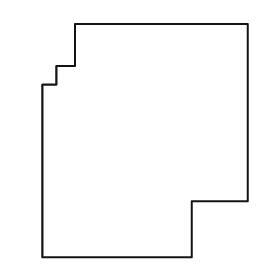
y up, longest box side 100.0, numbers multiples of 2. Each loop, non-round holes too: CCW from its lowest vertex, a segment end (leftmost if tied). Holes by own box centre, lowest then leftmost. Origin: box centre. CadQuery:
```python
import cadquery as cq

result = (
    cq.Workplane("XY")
    .moveTo(-44.0, -50.0)
    .lineTo(20.0, -50.0)
    .lineTo(20.0, -26.0)
    .lineTo(44.0, -26.0)
    .lineTo(44.0, 50.0)
    .lineTo(-30.0, 50.0)
    .lineTo(-30.0, 32.0)
    .lineTo(-38.0, 32.0)
    .lineTo(-38.0, 24.0)
    .lineTo(-44.0, 24.0)
    .close()
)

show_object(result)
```